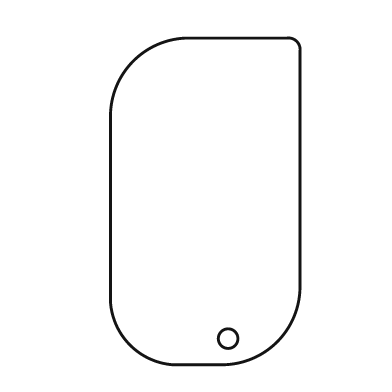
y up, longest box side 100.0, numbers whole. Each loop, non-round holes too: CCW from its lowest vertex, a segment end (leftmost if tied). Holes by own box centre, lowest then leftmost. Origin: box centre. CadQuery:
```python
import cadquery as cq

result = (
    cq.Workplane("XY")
    .moveTo(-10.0, -50.0)
    .lineTo(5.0, -50.0)
    .threePointArc((22.0, -43.0), (29.0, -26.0))
    .lineTo(29.0, 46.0)
    .threePointArc((28.0, 49.0), (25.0, 50.0))
    .lineTo(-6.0, 50.0)
    .threePointArc((-22.0, 43.0), (-29.0, 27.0))
    .lineTo(-29.0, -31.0)
    .threePointArc((-23.0, -44.0), (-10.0, -50.0))
    .close()
    .moveTo(7.0, -42.0)
    .circle(3.0)
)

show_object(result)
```